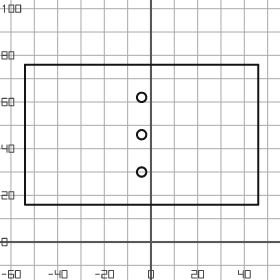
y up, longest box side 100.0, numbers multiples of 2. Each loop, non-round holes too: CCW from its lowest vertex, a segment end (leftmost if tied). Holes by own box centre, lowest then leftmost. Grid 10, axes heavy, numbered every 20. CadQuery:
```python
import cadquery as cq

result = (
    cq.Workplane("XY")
    .moveTo(-54.0, 16.0)
    .lineTo(46.0, 16.0)
    .lineTo(46.0, 76.0)
    .lineTo(-54.0, 76.0)
    .close()
    .moveTo(-4.0, 30.0)
    .circle(2.0)
    .moveTo(-4.0, 46.0)
    .circle(2.0)
    .moveTo(-4.0, 62.0)
    .circle(2.0)
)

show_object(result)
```